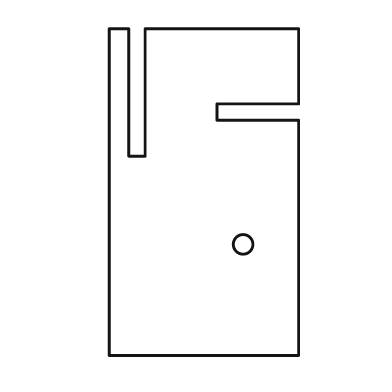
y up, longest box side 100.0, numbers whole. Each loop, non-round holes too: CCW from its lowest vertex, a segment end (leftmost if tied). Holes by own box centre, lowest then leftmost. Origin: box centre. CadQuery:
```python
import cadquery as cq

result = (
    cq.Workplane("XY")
    .moveTo(-29.0, -50.0)
    .lineTo(29.0, -50.0)
    .lineTo(29.0, 22.0)
    .lineTo(4.0, 22.0)
    .lineTo(4.0, 27.0)
    .lineTo(29.0, 27.0)
    .lineTo(29.0, 50.0)
    .lineTo(-18.0, 50.0)
    .lineTo(-18.0, 11.0)
    .lineTo(-23.0, 11.0)
    .lineTo(-23.0, 50.0)
    .lineTo(-29.0, 50.0)
    .close()
    .moveTo(12.0, -16.0)
    .circle(3.0)
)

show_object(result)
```